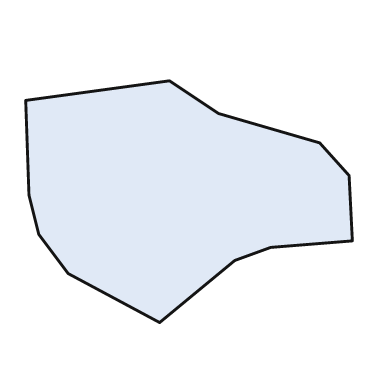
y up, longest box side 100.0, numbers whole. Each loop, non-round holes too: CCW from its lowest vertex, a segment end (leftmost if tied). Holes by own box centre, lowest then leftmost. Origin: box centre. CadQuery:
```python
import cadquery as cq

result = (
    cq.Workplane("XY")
    .moveTo(-9.0, -37.0)
    .lineTo(14.0, -18.0)
    .lineTo(25.0, -14.0)
    .lineTo(50.0, -12.0)
    .lineTo(49.0, 8.0)
    .lineTo(40.0, 18.0)
    .lineTo(9.0, 27.0)
    .lineTo(-6.0, 37.0)
    .lineTo(-50.0, 31.0)
    .lineTo(-49.0, 2.0)
    .lineTo(-46.0, -10.0)
    .lineTo(-37.0, -22.0)
    .close()
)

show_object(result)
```